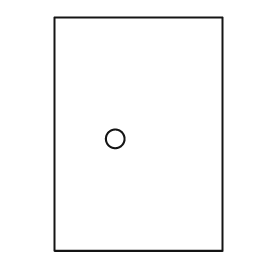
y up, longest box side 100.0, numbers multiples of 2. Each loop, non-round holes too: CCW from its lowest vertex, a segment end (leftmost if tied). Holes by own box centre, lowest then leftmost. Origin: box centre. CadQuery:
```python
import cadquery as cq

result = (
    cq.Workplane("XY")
    .moveTo(-36.0, -50.0)
    .lineTo(36.0, -50.0)
    .lineTo(36.0, 50.0)
    .lineTo(-36.0, 50.0)
    .close()
    .moveTo(-10.0, -2.0)
    .circle(4.0)
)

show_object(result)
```